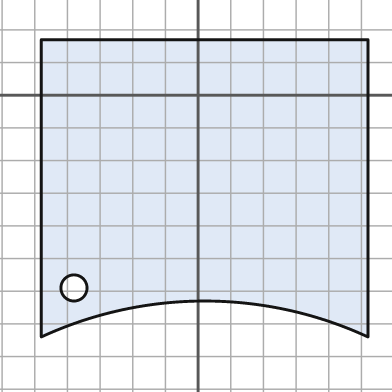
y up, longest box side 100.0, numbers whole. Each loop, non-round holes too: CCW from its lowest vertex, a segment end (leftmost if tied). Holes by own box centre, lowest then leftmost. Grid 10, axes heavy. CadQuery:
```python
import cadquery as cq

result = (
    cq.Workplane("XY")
    .moveTo(-48.0, -74.0)
    .threePointArc((2.0, -63.0), (52.0, -74.0))
    .lineTo(52.0, 17.0)
    .lineTo(-48.0, 17.0)
    .close()
    .moveTo(-38.0, -59.0)
    .circle(4.0)
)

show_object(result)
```